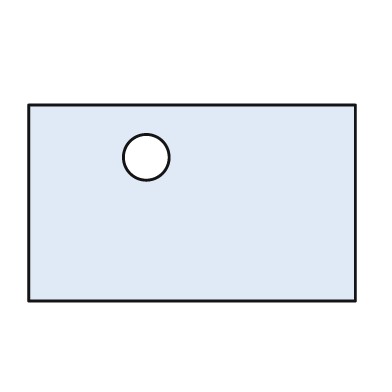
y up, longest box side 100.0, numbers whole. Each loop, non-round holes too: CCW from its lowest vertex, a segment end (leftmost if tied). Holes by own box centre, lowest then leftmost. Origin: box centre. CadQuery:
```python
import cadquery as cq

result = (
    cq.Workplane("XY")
    .moveTo(-50.0, -30.0)
    .lineTo(50.0, -30.0)
    .lineTo(50.0, 30.0)
    .lineTo(-50.0, 30.0)
    .close()
    .moveTo(-14.0, 14.0)
    .circle(7.0)
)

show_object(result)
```